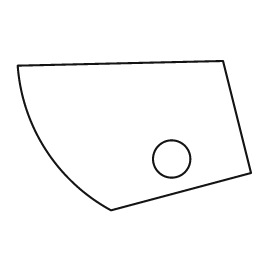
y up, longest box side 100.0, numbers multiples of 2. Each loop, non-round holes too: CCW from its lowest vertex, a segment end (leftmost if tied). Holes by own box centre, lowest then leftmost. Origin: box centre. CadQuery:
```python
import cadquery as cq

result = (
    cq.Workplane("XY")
    .moveTo(-10.0, -32.0)
    .lineTo(50.0, -16.0)
    .lineTo(38.0, 32.0)
    .lineTo(-50.0, 30.0)
    .threePointArc((-38.0, -6.0), (-10.0, -32.0))
    .close()
    .moveTo(16.0, -10.0)
    .circle(8.0)
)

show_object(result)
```